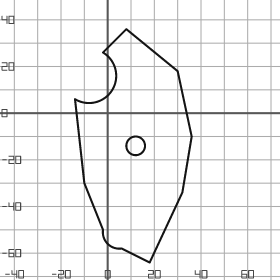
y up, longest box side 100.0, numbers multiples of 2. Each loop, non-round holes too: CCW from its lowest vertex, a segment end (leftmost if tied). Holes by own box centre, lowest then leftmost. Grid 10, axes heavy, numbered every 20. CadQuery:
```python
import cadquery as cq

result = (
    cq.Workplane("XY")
    .moveTo(18.0, -64.0)
    .lineTo(32.0, -34.0)
    .lineTo(36.0, -10.0)
    .lineTo(30.0, 18.0)
    .lineTo(8.0, 36.0)
    .lineTo(-2.0, 26.0)
    .threePointArc((2.0, 10.0), (-14.0, 6.0))
    .lineTo(-10.0, -30.0)
    .lineTo(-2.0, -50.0)
    .threePointArc((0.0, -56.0), (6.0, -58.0))
    .close()
    .moveTo(12.0, -14.0)
    .circle(4.0)
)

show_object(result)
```